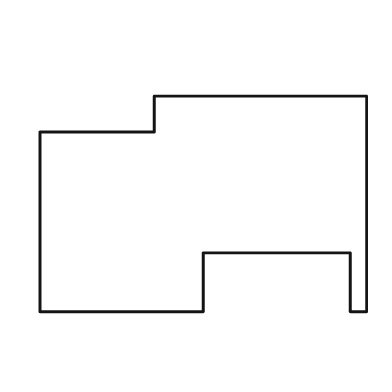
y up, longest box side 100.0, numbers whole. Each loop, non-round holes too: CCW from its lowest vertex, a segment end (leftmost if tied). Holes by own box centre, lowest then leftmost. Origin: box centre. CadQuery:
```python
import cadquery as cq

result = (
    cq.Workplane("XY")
    .moveTo(-50.0, -33.0)
    .lineTo(0.0, -33.0)
    .lineTo(0.0, -15.0)
    .lineTo(45.0, -15.0)
    .lineTo(45.0, -33.0)
    .lineTo(50.0, -33.0)
    .lineTo(50.0, 33.0)
    .lineTo(-15.0, 33.0)
    .lineTo(-15.0, 22.0)
    .lineTo(-50.0, 22.0)
    .close()
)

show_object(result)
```